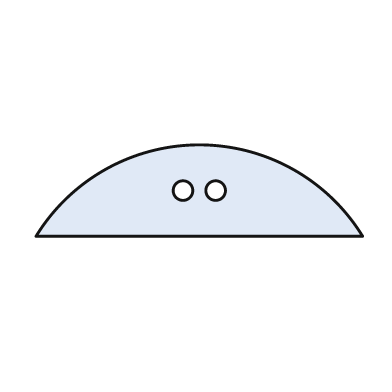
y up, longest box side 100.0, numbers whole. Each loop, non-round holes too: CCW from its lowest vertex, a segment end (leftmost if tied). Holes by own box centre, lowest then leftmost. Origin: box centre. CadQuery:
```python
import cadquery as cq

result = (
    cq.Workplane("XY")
    .moveTo(-50.0, -14.0)
    .lineTo(50.0, -14.0)
    .threePointArc((0.0, 14.0), (-50.0, -14.0))
    .close()
    .moveTo(-5.0, 0.0)
    .circle(3.0)
    .moveTo(5.0, 0.0)
    .circle(3.0)
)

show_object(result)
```